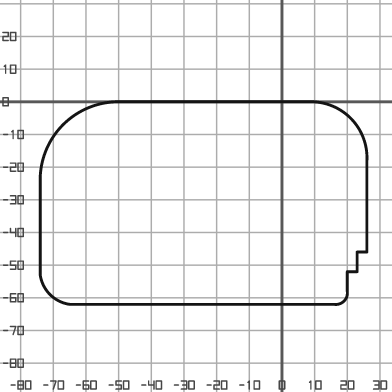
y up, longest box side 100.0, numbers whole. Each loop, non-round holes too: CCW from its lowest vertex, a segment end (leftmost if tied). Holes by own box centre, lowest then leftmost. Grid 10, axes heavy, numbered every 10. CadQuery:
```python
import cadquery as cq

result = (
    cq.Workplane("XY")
    .moveTo(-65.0, -62.0)
    .lineTo(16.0, -62.0)
    .threePointArc((19.0, -61.0), (20.0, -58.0))
    .lineTo(20.0, -52.0)
    .lineTo(23.0, -52.0)
    .lineTo(23.0, -46.0)
    .lineTo(26.0, -46.0)
    .lineTo(26.0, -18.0)
    .threePointArc((21.0, -5.0), (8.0, 0.0))
    .lineTo(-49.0, 0.0)
    .threePointArc((-67.0, -7.0), (-74.0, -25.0))
    .lineTo(-74.0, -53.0)
    .threePointArc((-71.0, -59.0), (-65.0, -62.0))
    .close()
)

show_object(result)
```